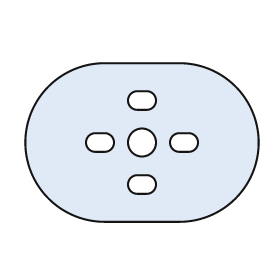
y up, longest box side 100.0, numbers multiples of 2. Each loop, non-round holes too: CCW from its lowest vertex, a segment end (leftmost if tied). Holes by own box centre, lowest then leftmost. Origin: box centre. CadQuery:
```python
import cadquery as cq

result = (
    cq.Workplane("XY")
    .moveTo(-16.0, -34.0)
    .lineTo(16.0, -34.0)
    .threePointArc((50.0, 0.0), (16.0, 34.0))
    .lineTo(-16.0, 34.0)
    .threePointArc((-50.0, 0.0), (-16.0, -34.0))
    .close()
    .moveTo(-2.0, -22.0)
    .lineTo(2.0, -22.0)
    .threePointArc((6.0, -18.0), (2.0, -14.0))
    .lineTo(-2.0, -14.0)
    .threePointArc((-6.0, -18.0), (-2.0, -22.0))
    .close()
    .moveTo(-20.0, -4.0)
    .lineTo(-16.0, -4.0)
    .threePointArc((-12.0, 0.0), (-16.0, 4.0))
    .lineTo(-20.0, 4.0)
    .threePointArc((-24.0, 0.0), (-20.0, -4.0))
    .close()
    .moveTo(0.0, 0.0)
    .circle(6.0)
    .moveTo(16.0, -4.0)
    .lineTo(20.0, -4.0)
    .threePointArc((24.0, 0.0), (20.0, 4.0))
    .lineTo(16.0, 4.0)
    .threePointArc((12.0, 0.0), (16.0, -4.0))
    .close()
    .moveTo(-2.0, 14.0)
    .lineTo(2.0, 14.0)
    .threePointArc((6.0, 18.0), (2.0, 22.0))
    .lineTo(-2.0, 22.0)
    .threePointArc((-6.0, 18.0), (-2.0, 14.0))
    .close()
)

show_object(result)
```